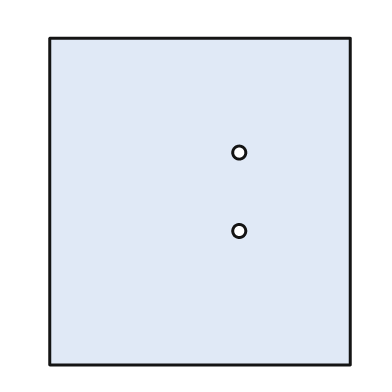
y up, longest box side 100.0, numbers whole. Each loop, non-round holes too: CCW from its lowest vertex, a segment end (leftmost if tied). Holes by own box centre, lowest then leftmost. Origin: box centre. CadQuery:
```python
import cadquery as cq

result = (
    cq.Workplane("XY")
    .moveTo(-46.0, -50.0)
    .lineTo(46.0, -50.0)
    .lineTo(46.0, 50.0)
    .lineTo(-46.0, 50.0)
    .close()
    .moveTo(12.0, -9.0)
    .circle(2.0)
    .moveTo(12.0, 15.0)
    .circle(2.0)
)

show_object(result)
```